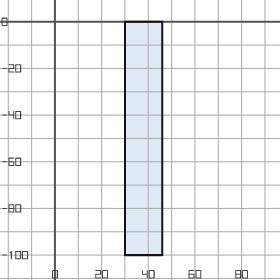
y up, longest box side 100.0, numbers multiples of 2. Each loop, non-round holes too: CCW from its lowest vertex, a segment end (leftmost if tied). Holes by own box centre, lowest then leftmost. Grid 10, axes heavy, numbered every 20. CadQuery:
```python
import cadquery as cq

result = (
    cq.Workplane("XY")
    .moveTo(30.0, -100.0)
    .lineTo(46.0, -100.0)
    .lineTo(46.0, 0.0)
    .lineTo(30.0, 0.0)
    .close()
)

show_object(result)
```